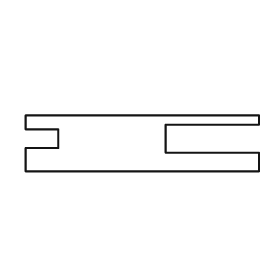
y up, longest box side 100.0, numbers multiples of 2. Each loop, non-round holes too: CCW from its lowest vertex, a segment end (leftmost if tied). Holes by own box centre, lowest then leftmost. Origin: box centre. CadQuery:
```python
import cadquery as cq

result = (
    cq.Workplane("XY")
    .moveTo(-50.0, -12.0)
    .lineTo(50.0, -12.0)
    .lineTo(50.0, -4.0)
    .lineTo(10.0, -4.0)
    .lineTo(10.0, 8.0)
    .lineTo(50.0, 8.0)
    .lineTo(50.0, 12.0)
    .lineTo(-50.0, 12.0)
    .lineTo(-50.0, 6.0)
    .lineTo(-36.0, 6.0)
    .lineTo(-36.0, -2.0)
    .lineTo(-50.0, -2.0)
    .close()
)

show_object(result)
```